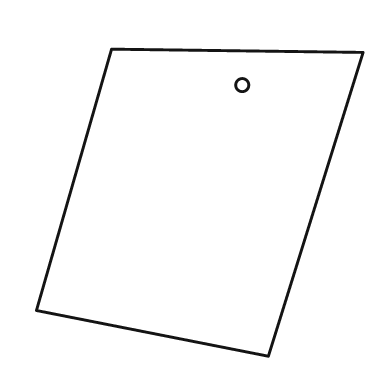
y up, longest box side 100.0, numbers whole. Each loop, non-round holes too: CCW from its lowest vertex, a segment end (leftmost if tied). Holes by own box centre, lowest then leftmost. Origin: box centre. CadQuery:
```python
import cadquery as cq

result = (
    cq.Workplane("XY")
    .moveTo(21.0, -47.0)
    .lineTo(50.0, 46.0)
    .lineTo(-27.0, 47.0)
    .lineTo(-50.0, -33.0)
    .close()
    .moveTo(13.0, 36.0)
    .circle(2.0)
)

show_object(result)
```